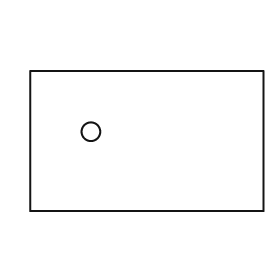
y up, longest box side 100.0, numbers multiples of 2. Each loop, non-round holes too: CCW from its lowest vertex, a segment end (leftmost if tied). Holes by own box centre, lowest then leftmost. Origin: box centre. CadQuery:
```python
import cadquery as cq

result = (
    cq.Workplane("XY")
    .moveTo(-50.0, -30.0)
    .lineTo(50.0, -30.0)
    .lineTo(50.0, 30.0)
    .lineTo(-50.0, 30.0)
    .close()
    .moveTo(-24.0, 4.0)
    .circle(4.0)
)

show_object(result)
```